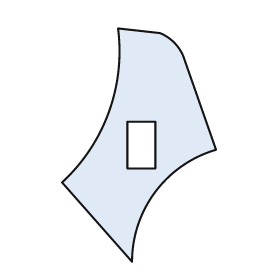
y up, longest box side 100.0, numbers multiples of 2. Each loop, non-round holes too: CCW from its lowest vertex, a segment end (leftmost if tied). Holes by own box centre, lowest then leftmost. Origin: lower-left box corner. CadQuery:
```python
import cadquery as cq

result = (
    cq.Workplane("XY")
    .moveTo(30.0, 0.0)
    .threePointArc((40.0, 30.0), (66.0, 48.0))
    .lineTo(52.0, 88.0)
    .threePointArc((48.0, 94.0), (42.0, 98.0))
    .lineTo(24.0, 100.0)
    .threePointArc((20.0, 64.0), (0.0, 34.0))
    .close()
    .moveTo(28.0, 40.0)
    .lineTo(40.0, 40.0)
    .lineTo(40.0, 60.0)
    .lineTo(28.0, 60.0)
    .close()
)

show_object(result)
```